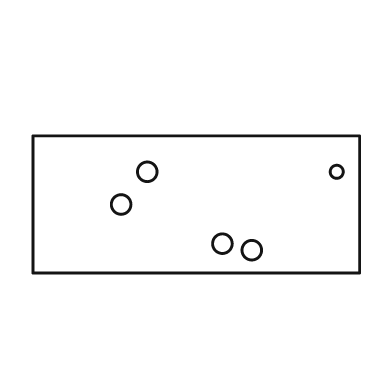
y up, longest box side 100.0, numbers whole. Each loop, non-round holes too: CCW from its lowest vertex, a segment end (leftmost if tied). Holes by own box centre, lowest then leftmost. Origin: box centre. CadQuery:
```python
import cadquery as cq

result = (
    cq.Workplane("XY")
    .moveTo(-50.0, -21.0)
    .lineTo(50.0, -21.0)
    .lineTo(50.0, 21.0)
    .lineTo(-50.0, 21.0)
    .close()
    .moveTo(17.0, -14.0)
    .circle(3.0)
    .moveTo(8.0, -12.0)
    .circle(3.0)
    .moveTo(-23.0, 0.0)
    .circle(3.0)
    .moveTo(-15.0, 10.0)
    .circle(3.0)
    .moveTo(43.0, 10.0)
    .circle(2.0)
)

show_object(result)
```